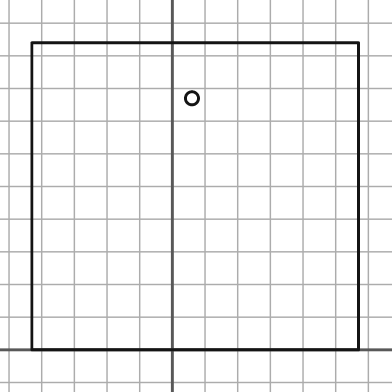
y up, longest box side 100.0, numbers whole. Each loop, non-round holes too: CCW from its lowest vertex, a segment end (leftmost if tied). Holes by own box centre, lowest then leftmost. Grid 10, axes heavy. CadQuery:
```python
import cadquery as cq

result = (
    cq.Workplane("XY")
    .moveTo(-43.0, 0.0)
    .lineTo(57.0, 0.0)
    .lineTo(57.0, 94.0)
    .lineTo(-43.0, 94.0)
    .close()
    .moveTo(6.0, 77.0)
    .circle(2.0)
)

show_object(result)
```